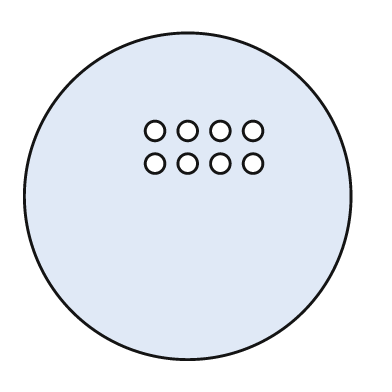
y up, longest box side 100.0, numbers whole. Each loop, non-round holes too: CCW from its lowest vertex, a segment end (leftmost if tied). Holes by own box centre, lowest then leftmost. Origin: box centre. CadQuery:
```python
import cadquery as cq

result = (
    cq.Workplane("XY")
    .moveTo(0.0, 0.0)
    .circle(50.0)
    .moveTo(-10.0, 10.0)
    .circle(3.0)
    .moveTo(0.0, 10.0)
    .circle(3.0)
    .moveTo(10.0, 10.0)
    .circle(3.0)
    .moveTo(20.0, 10.0)
    .circle(3.0)
    .moveTo(-10.0, 20.0)
    .circle(3.0)
    .moveTo(0.0, 20.0)
    .circle(3.0)
    .moveTo(10.0, 20.0)
    .circle(3.0)
    .moveTo(20.0, 20.0)
    .circle(3.0)
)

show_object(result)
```